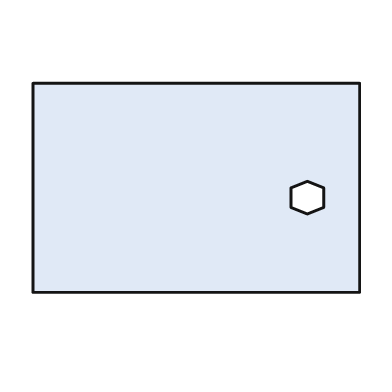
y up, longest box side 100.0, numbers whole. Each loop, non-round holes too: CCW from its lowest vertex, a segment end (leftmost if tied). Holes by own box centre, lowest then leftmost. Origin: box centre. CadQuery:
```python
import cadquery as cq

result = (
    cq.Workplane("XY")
    .moveTo(-50.0, -32.0)
    .lineTo(50.0, -32.0)
    .lineTo(50.0, 32.0)
    .lineTo(-50.0, 32.0)
    .close()
    .moveTo(34.0, -8.0)
    .lineTo(39.0, -6.0)
    .lineTo(39.0, 0.0)
    .lineTo(34.0, 2.0)
    .lineTo(29.0, 0.0)
    .lineTo(29.0, -6.0)
    .close()
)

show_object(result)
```